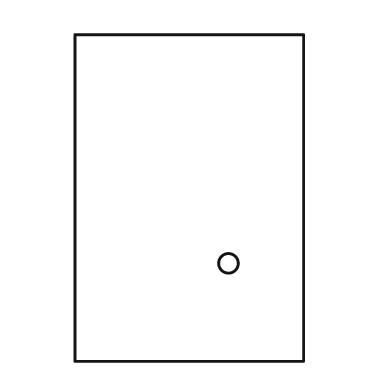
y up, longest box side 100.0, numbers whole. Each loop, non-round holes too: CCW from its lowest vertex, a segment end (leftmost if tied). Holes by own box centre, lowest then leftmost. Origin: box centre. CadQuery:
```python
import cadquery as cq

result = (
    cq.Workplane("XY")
    .moveTo(-35.0, -50.0)
    .lineTo(35.0, -50.0)
    .lineTo(35.0, 50.0)
    .lineTo(-35.0, 50.0)
    .close()
    .moveTo(12.0, -20.0)
    .circle(3.0)
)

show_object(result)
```